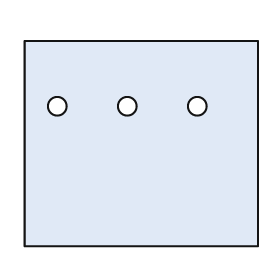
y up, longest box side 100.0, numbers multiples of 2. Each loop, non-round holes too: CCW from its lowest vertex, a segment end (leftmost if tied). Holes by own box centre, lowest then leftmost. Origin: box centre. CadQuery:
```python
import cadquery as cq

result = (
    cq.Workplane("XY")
    .moveTo(-50.0, -44.0)
    .lineTo(50.0, -44.0)
    .lineTo(50.0, 44.0)
    .lineTo(-50.0, 44.0)
    .close()
    .moveTo(-36.0, 16.0)
    .circle(4.0)
    .moveTo(-6.0, 16.0)
    .circle(4.0)
    .moveTo(24.0, 16.0)
    .circle(4.0)
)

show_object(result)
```